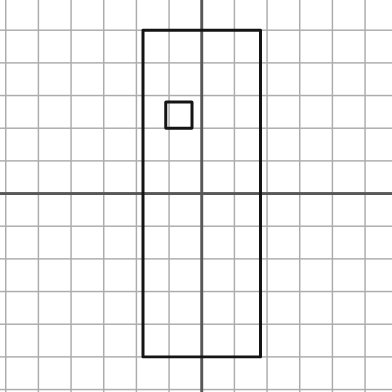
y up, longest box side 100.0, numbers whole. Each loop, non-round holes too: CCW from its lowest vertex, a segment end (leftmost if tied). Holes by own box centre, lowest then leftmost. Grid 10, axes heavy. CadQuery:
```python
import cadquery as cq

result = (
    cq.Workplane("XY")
    .moveTo(-18.0, -50.0)
    .lineTo(18.0, -50.0)
    .lineTo(18.0, 50.0)
    .lineTo(-18.0, 50.0)
    .close()
    .moveTo(-11.0, 20.0)
    .lineTo(-3.0, 20.0)
    .lineTo(-3.0, 28.0)
    .lineTo(-11.0, 28.0)
    .close()
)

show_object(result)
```